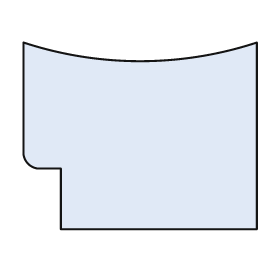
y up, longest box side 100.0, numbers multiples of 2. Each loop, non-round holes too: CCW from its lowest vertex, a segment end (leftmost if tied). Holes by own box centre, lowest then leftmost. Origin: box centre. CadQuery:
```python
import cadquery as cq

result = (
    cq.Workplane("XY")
    .moveTo(-34.0, -40.0)
    .lineTo(50.0, -40.0)
    .lineTo(50.0, 40.0)
    .threePointArc((0.0, 32.0), (-50.0, 40.0))
    .lineTo(-50.0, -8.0)
    .threePointArc((-48.0, -12.0), (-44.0, -14.0))
    .lineTo(-34.0, -14.0)
    .close()
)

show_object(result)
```